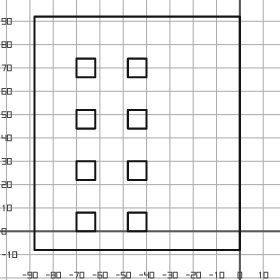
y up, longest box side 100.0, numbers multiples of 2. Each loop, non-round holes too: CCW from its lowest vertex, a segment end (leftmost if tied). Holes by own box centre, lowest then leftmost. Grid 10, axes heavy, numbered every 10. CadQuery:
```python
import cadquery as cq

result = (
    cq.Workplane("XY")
    .moveTo(-88.0, -8.0)
    .lineTo(0.0, -8.0)
    .lineTo(0.0, 92.0)
    .lineTo(-88.0, 92.0)
    .close()
    .moveTo(-70.0, 0.0)
    .lineTo(-62.0, 0.0)
    .lineTo(-62.0, 8.0)
    .lineTo(-70.0, 8.0)
    .close()
    .moveTo(-48.0, 0.0)
    .lineTo(-40.0, 0.0)
    .lineTo(-40.0, 8.0)
    .lineTo(-48.0, 8.0)
    .close()
    .moveTo(-70.0, 22.0)
    .lineTo(-62.0, 22.0)
    .lineTo(-62.0, 30.0)
    .lineTo(-70.0, 30.0)
    .close()
    .moveTo(-48.0, 22.0)
    .lineTo(-40.0, 22.0)
    .lineTo(-40.0, 30.0)
    .lineTo(-48.0, 30.0)
    .close()
    .moveTo(-70.0, 44.0)
    .lineTo(-62.0, 44.0)
    .lineTo(-62.0, 52.0)
    .lineTo(-70.0, 52.0)
    .close()
    .moveTo(-48.0, 44.0)
    .lineTo(-40.0, 44.0)
    .lineTo(-40.0, 52.0)
    .lineTo(-48.0, 52.0)
    .close()
    .moveTo(-70.0, 66.0)
    .lineTo(-62.0, 66.0)
    .lineTo(-62.0, 74.0)
    .lineTo(-70.0, 74.0)
    .close()
    .moveTo(-48.0, 66.0)
    .lineTo(-40.0, 66.0)
    .lineTo(-40.0, 74.0)
    .lineTo(-48.0, 74.0)
    .close()
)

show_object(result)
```